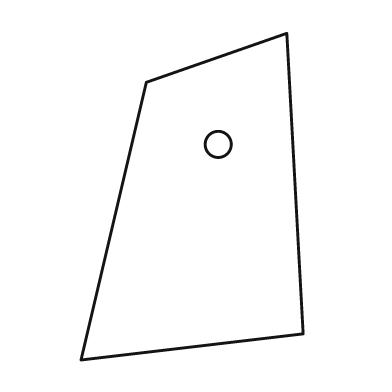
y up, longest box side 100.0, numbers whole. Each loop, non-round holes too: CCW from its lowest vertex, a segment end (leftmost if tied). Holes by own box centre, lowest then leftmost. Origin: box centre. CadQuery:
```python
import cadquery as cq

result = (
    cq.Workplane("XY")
    .moveTo(-34.0, -50.0)
    .lineTo(34.0, -42.0)
    .lineTo(29.0, 50.0)
    .lineTo(-14.0, 35.0)
    .close()
    .moveTo(8.0, 16.0)
    .circle(4.0)
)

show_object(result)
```